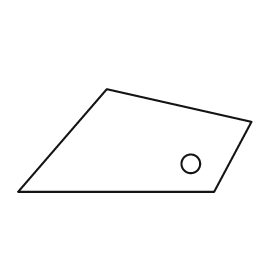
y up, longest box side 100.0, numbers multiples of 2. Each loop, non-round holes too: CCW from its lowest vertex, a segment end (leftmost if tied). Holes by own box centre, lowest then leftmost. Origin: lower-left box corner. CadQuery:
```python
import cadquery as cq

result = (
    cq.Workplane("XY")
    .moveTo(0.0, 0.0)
    .lineTo(84.0, 0.0)
    .lineTo(100.0, 30.0)
    .lineTo(38.0, 44.0)
    .close()
    .moveTo(74.0, 12.0)
    .circle(4.0)
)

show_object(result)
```